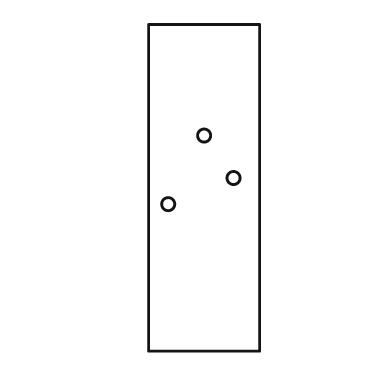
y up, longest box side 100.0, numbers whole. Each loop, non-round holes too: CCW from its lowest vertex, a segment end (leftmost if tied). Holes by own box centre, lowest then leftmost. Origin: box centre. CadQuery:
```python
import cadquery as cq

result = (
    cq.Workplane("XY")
    .moveTo(-17.0, -50.0)
    .lineTo(17.0, -50.0)
    .lineTo(17.0, 50.0)
    .lineTo(-17.0, 50.0)
    .close()
    .moveTo(-11.0, -5.0)
    .circle(2.0)
    .moveTo(9.0, 3.0)
    .circle(2.0)
    .moveTo(0.0, 16.0)
    .circle(2.0)
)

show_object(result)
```